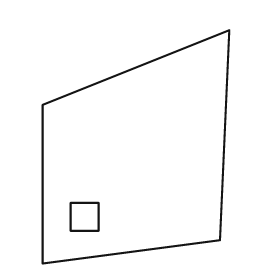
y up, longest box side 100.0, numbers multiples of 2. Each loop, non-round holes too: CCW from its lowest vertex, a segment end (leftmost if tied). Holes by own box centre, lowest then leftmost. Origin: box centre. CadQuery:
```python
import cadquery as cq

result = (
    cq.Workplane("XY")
    .moveTo(-40.0, -50.0)
    .lineTo(36.0, -40.0)
    .lineTo(40.0, 50.0)
    .lineTo(-40.0, 18.0)
    .close()
    .moveTo(-28.0, -36.0)
    .lineTo(-16.0, -36.0)
    .lineTo(-16.0, -24.0)
    .lineTo(-28.0, -24.0)
    .close()
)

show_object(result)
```